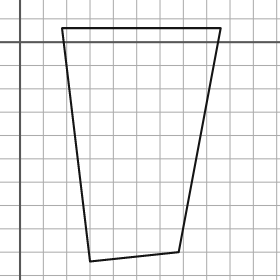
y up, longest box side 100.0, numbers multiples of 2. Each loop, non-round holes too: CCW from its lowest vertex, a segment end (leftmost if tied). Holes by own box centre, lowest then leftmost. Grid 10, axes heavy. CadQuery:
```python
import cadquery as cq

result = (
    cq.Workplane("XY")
    .moveTo(30.0, -94.0)
    .lineTo(68.0, -90.0)
    .lineTo(86.0, 6.0)
    .lineTo(18.0, 6.0)
    .close()
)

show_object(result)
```